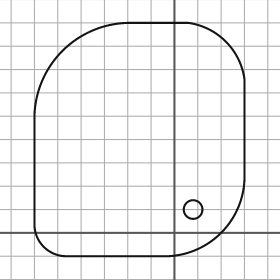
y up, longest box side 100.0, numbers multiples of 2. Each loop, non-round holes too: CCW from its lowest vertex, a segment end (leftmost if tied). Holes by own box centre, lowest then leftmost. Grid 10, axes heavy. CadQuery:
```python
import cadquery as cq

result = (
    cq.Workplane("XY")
    .moveTo(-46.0, -10.0)
    .lineTo(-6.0, -10.0)
    .threePointArc((20.0, 0.0), (30.0, 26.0))
    .lineTo(30.0, 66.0)
    .threePointArc((22.0, 82.0), (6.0, 90.0))
    .lineTo(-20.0, 90.0)
    .threePointArc((-48.0, 78.0), (-60.0, 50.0))
    .lineTo(-60.0, 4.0)
    .threePointArc((-56.0, -6.0), (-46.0, -10.0))
    .close()
    .moveTo(8.0, 10.0)
    .circle(4.0)
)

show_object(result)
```